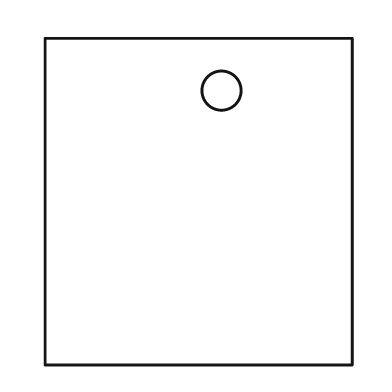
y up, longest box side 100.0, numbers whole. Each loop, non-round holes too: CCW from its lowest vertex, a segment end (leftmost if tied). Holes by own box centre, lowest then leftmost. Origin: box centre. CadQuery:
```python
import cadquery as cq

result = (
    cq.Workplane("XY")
    .moveTo(-47.0, -50.0)
    .lineTo(47.0, -50.0)
    .lineTo(47.0, 50.0)
    .lineTo(-47.0, 50.0)
    .close()
    .moveTo(7.0, 34.0)
    .circle(6.0)
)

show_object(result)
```